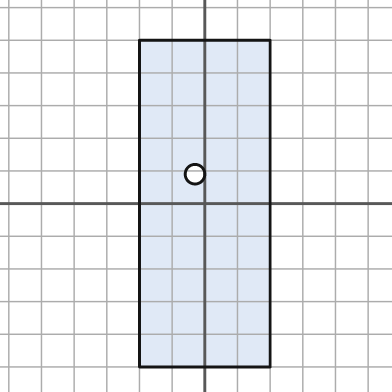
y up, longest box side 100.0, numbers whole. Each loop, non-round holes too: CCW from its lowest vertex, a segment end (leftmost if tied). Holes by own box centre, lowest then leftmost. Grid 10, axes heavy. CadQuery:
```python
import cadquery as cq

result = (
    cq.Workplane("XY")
    .moveTo(-20.0, -50.0)
    .lineTo(20.0, -50.0)
    .lineTo(20.0, 50.0)
    .lineTo(-20.0, 50.0)
    .close()
    .moveTo(-3.0, 9.0)
    .circle(3.0)
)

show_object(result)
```